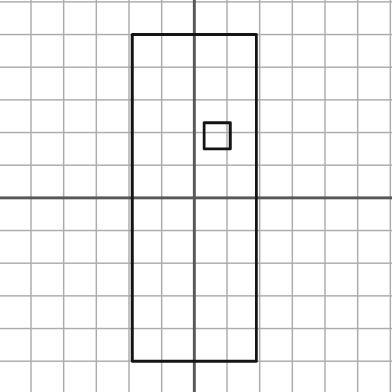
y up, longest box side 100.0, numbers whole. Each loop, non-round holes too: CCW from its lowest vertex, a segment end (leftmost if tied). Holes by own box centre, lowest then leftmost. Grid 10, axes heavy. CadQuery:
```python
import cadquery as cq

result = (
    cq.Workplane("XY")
    .moveTo(-19.0, -50.0)
    .lineTo(19.0, -50.0)
    .lineTo(19.0, 50.0)
    .lineTo(-19.0, 50.0)
    .close()
    .moveTo(3.0, 15.0)
    .lineTo(11.0, 15.0)
    .lineTo(11.0, 23.0)
    .lineTo(3.0, 23.0)
    .close()
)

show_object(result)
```